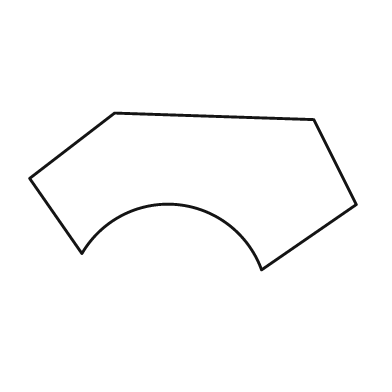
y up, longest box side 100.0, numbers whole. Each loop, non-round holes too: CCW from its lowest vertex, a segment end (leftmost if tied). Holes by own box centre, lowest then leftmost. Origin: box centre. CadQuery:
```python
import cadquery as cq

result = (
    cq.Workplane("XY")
    .moveTo(21.0, -24.0)
    .lineTo(50.0, -4.0)
    .lineTo(37.0, 22.0)
    .lineTo(-24.0, 24.0)
    .lineTo(-50.0, 4.0)
    .lineTo(-34.0, -19.0)
    .threePointArc((-5.0, -4.0), (21.0, -24.0))
    .close()
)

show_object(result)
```